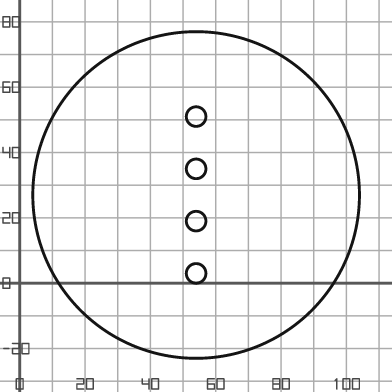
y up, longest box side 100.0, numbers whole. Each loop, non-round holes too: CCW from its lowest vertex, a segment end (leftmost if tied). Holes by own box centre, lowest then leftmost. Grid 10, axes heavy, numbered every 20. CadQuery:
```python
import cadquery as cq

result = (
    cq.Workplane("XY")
    .moveTo(54.0, 27.0)
    .circle(50.0)
    .moveTo(54.0, 3.0)
    .circle(3.0)
    .moveTo(54.0, 19.0)
    .circle(3.0)
    .moveTo(54.0, 35.0)
    .circle(3.0)
    .moveTo(54.0, 51.0)
    .circle(3.0)
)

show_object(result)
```